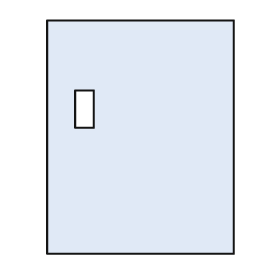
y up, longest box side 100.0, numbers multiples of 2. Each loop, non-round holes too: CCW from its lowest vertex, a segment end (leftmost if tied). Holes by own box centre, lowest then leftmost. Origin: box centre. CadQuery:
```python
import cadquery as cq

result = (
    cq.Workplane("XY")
    .moveTo(-40.0, -50.0)
    .lineTo(40.0, -50.0)
    .lineTo(40.0, 50.0)
    .lineTo(-40.0, 50.0)
    .close()
    .moveTo(-28.0, 4.0)
    .lineTo(-20.0, 4.0)
    .lineTo(-20.0, 20.0)
    .lineTo(-28.0, 20.0)
    .close()
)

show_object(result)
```